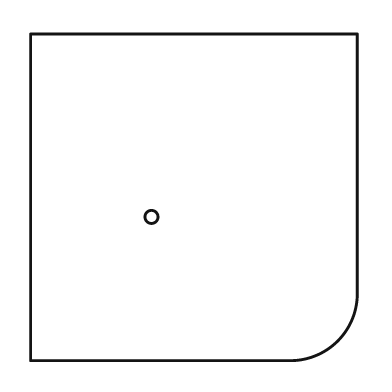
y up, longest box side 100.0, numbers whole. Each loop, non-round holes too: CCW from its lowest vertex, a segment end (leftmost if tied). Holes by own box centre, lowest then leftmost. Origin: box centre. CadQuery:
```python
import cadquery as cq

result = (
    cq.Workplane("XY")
    .moveTo(-50.0, -50.0)
    .lineTo(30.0, -50.0)
    .threePointArc((44.0, -44.0), (50.0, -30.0))
    .lineTo(50.0, 50.0)
    .lineTo(-50.0, 50.0)
    .close()
    .moveTo(-13.0, -6.0)
    .circle(2.0)
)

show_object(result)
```